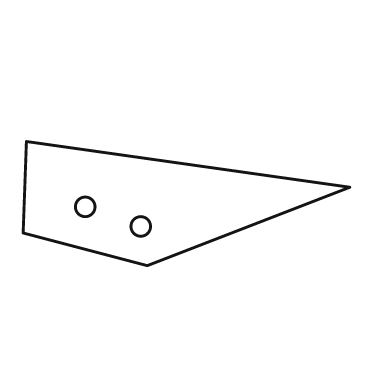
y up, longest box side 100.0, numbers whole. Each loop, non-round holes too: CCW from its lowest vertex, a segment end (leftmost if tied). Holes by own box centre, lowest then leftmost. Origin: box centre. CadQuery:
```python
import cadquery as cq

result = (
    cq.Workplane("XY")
    .moveTo(-12.0, -19.0)
    .lineTo(50.0, 5.0)
    .lineTo(-49.0, 19.0)
    .lineTo(-50.0, -9.0)
    .close()
    .moveTo(-14.0, -7.0)
    .circle(3.0)
    .moveTo(-31.0, -1.0)
    .circle(3.0)
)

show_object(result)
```